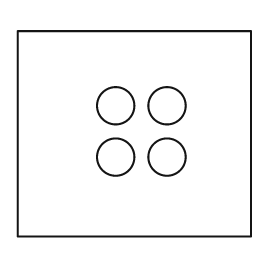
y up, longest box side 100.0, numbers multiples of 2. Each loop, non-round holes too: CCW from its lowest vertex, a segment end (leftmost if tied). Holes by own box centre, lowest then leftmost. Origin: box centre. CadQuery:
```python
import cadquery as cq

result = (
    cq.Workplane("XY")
    .moveTo(-50.0, -44.0)
    .lineTo(50.0, -44.0)
    .lineTo(50.0, 44.0)
    .lineTo(-50.0, 44.0)
    .close()
    .moveTo(-8.0, -10.0)
    .circle(8.0)
    .moveTo(14.0, -10.0)
    .circle(8.0)
    .moveTo(-8.0, 12.0)
    .circle(8.0)
    .moveTo(14.0, 12.0)
    .circle(8.0)
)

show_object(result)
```